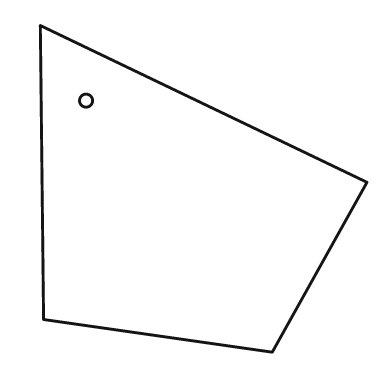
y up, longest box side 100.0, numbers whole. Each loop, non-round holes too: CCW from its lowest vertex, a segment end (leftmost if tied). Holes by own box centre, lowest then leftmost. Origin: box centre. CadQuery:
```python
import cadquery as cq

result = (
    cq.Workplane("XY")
    .moveTo(21.0, -50.0)
    .lineTo(50.0, 2.0)
    .lineTo(-50.0, 50.0)
    .lineTo(-49.0, -40.0)
    .close()
    .moveTo(-36.0, 27.0)
    .circle(2.0)
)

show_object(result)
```